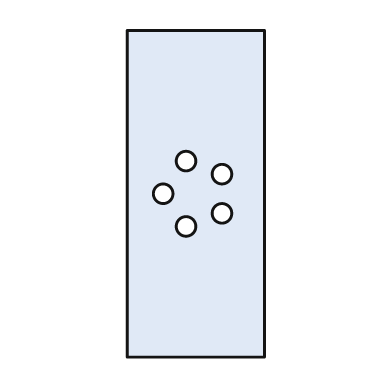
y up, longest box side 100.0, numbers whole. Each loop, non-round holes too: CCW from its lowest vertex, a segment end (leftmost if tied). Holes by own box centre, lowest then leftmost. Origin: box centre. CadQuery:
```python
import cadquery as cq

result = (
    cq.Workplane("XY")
    .moveTo(-21.0, -50.0)
    .lineTo(21.0, -50.0)
    .lineTo(21.0, 50.0)
    .lineTo(-21.0, 50.0)
    .close()
    .moveTo(-3.0, -10.0)
    .circle(3.0)
    .moveTo(8.0, -6.0)
    .circle(3.0)
    .moveTo(-10.0, 0.0)
    .circle(3.0)
    .moveTo(8.0, 6.0)
    .circle(3.0)
    .moveTo(-3.0, 10.0)
    .circle(3.0)
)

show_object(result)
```